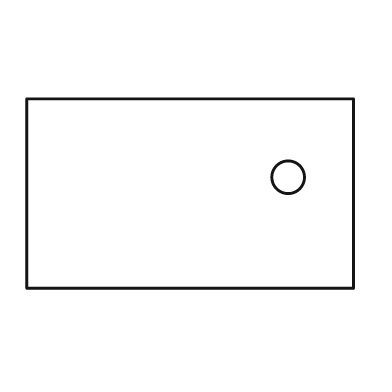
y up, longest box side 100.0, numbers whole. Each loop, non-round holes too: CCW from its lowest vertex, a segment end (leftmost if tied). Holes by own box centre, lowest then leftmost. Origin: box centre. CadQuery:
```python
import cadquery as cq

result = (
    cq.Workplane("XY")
    .moveTo(-50.0, -29.0)
    .lineTo(50.0, -29.0)
    .lineTo(50.0, 29.0)
    .lineTo(-50.0, 29.0)
    .close()
    .moveTo(30.0, 5.0)
    .circle(5.0)
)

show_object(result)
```